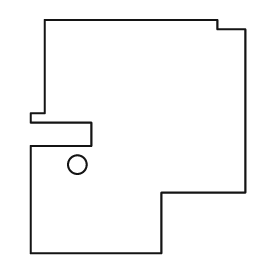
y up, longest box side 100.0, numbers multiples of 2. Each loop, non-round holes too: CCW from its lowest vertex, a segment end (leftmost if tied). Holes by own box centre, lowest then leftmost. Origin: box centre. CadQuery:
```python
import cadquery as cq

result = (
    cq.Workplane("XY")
    .moveTo(-46.0, -50.0)
    .lineTo(10.0, -50.0)
    .lineTo(10.0, -24.0)
    .lineTo(46.0, -24.0)
    .lineTo(46.0, 46.0)
    .lineTo(34.0, 46.0)
    .lineTo(34.0, 50.0)
    .lineTo(-40.0, 50.0)
    .lineTo(-40.0, 10.0)
    .lineTo(-46.0, 10.0)
    .lineTo(-46.0, 6.0)
    .lineTo(-20.0, 6.0)
    .lineTo(-20.0, -4.0)
    .lineTo(-46.0, -4.0)
    .close()
    .moveTo(-26.0, -12.0)
    .circle(4.0)
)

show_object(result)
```